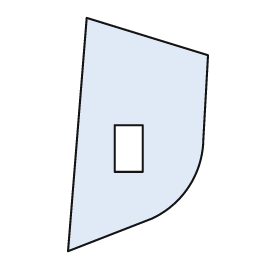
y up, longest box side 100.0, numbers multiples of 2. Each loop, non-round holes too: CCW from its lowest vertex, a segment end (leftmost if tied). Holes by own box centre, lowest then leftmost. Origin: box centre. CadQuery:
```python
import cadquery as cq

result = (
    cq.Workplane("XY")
    .moveTo(-30.0, -50.0)
    .lineTo(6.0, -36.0)
    .threePointArc((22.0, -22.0), (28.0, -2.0))
    .lineTo(30.0, 34.0)
    .lineTo(-22.0, 50.0)
    .close()
    .moveTo(-10.0, -16.0)
    .lineTo(2.0, -16.0)
    .lineTo(2.0, 4.0)
    .lineTo(-10.0, 4.0)
    .close()
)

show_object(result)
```